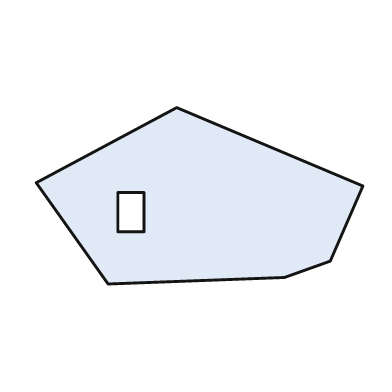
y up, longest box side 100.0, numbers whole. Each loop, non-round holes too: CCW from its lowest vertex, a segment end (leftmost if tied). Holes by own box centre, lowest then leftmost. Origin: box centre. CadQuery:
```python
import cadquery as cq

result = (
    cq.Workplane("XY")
    .moveTo(-28.0, -27.0)
    .lineTo(26.0, -25.0)
    .lineTo(40.0, -20.0)
    .lineTo(50.0, 3.0)
    .lineTo(-7.0, 27.0)
    .lineTo(-50.0, 4.0)
    .close()
    .moveTo(-25.0, -11.0)
    .lineTo(-17.0, -11.0)
    .lineTo(-17.0, 1.0)
    .lineTo(-25.0, 1.0)
    .close()
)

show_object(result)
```